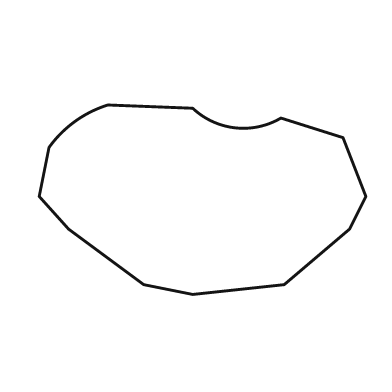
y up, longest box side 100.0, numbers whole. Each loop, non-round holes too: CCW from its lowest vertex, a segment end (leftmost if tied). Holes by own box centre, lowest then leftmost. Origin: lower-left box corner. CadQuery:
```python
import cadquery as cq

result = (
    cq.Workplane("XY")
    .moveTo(47.0, 0.0)
    .lineTo(75.0, 3.0)
    .lineTo(95.0, 20.0)
    .lineTo(100.0, 30.0)
    .lineTo(93.0, 48.0)
    .lineTo(74.0, 54.0)
    .threePointArc((60.0, 51.0), (47.0, 57.0))
    .lineTo(21.0, 58.0)
    .threePointArc((11.0, 53.0), (3.0, 45.0))
    .lineTo(0.0, 30.0)
    .lineTo(9.0, 20.0)
    .lineTo(32.0, 3.0)
    .close()
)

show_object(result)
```